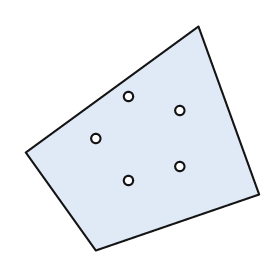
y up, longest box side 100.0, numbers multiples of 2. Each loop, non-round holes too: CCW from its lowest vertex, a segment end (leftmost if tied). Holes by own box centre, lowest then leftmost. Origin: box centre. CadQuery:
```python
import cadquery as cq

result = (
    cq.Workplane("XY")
    .moveTo(-20.0, -48.0)
    .lineTo(50.0, -24.0)
    .lineTo(24.0, 48.0)
    .lineTo(-50.0, -6.0)
    .close()
    .moveTo(-6.0, -18.0)
    .circle(2.0)
    .moveTo(16.0, -12.0)
    .circle(2.0)
    .moveTo(-20.0, 0.0)
    .circle(2.0)
    .moveTo(16.0, 12.0)
    .circle(2.0)
    .moveTo(-6.0, 18.0)
    .circle(2.0)
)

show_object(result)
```